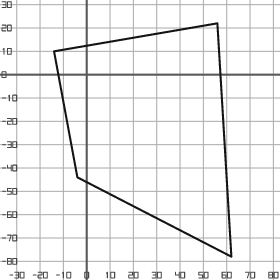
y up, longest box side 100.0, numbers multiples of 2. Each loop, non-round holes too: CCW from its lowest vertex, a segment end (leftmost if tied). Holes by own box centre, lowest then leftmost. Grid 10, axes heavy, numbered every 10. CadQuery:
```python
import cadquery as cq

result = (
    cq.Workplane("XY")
    .moveTo(62.0, -78.0)
    .lineTo(56.0, 22.0)
    .lineTo(-14.0, 10.0)
    .lineTo(-4.0, -44.0)
    .close()
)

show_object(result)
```